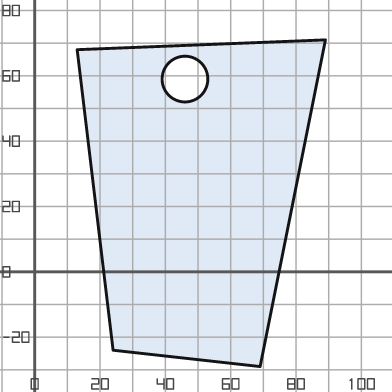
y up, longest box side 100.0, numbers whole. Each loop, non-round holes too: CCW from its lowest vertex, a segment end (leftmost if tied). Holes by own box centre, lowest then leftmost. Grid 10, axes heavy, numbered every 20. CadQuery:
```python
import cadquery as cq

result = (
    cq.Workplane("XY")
    .moveTo(69.0, -29.0)
    .lineTo(89.0, 71.0)
    .lineTo(13.0, 68.0)
    .lineTo(24.0, -24.0)
    .close()
    .moveTo(46.0, 59.0)
    .circle(7.0)
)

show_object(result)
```